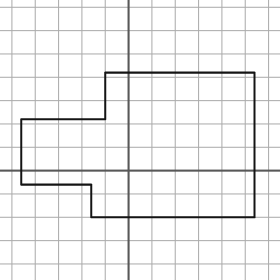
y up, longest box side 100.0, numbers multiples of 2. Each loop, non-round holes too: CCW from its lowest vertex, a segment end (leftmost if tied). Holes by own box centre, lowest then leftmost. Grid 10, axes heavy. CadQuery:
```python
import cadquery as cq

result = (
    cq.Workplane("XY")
    .moveTo(-16.0, -20.0)
    .lineTo(54.0, -20.0)
    .lineTo(54.0, 42.0)
    .lineTo(-10.0, 42.0)
    .lineTo(-10.0, 22.0)
    .lineTo(-46.0, 22.0)
    .lineTo(-46.0, -6.0)
    .lineTo(-16.0, -6.0)
    .close()
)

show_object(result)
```